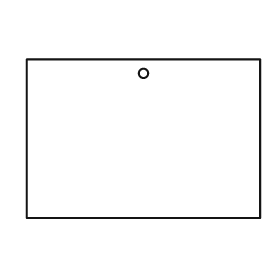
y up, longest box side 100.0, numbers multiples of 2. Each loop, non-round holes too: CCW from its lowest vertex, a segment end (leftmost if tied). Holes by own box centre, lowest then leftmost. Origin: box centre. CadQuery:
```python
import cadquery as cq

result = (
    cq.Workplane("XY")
    .moveTo(-50.0, -34.0)
    .lineTo(50.0, -34.0)
    .lineTo(50.0, 34.0)
    .lineTo(-50.0, 34.0)
    .close()
    .moveTo(0.0, 28.0)
    .circle(2.0)
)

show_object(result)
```